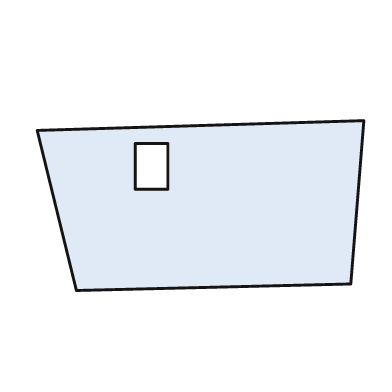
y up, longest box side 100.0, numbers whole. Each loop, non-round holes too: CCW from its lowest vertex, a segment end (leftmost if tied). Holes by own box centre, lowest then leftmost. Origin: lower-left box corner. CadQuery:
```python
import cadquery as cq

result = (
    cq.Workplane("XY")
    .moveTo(12.0, 0.0)
    .lineTo(96.0, 2.0)
    .lineTo(100.0, 52.0)
    .lineTo(0.0, 49.0)
    .close()
    .moveTo(30.0, 31.0)
    .lineTo(40.0, 31.0)
    .lineTo(40.0, 45.0)
    .lineTo(30.0, 45.0)
    .close()
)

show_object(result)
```